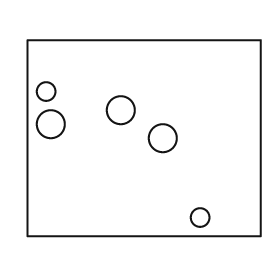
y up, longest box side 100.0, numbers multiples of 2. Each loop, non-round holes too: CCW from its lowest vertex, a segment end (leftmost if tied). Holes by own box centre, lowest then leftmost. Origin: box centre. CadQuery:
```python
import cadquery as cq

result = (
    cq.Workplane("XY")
    .moveTo(-50.0, -42.0)
    .lineTo(50.0, -42.0)
    .lineTo(50.0, 42.0)
    .lineTo(-50.0, 42.0)
    .close()
    .moveTo(24.0, -34.0)
    .circle(4.0)
    .moveTo(8.0, 0.0)
    .circle(6.0)
    .moveTo(-40.0, 6.0)
    .circle(6.0)
    .moveTo(-10.0, 12.0)
    .circle(6.0)
    .moveTo(-42.0, 20.0)
    .circle(4.0)
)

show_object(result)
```